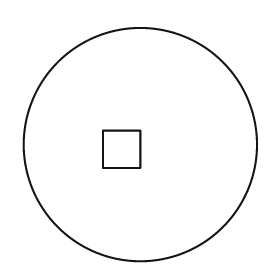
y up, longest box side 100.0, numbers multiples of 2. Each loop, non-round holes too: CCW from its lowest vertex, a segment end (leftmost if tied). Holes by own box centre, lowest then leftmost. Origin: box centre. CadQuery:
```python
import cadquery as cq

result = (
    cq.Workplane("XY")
    .moveTo(0.0, 0.0)
    .circle(50.0)
    .moveTo(-16.0, -10.0)
    .lineTo(0.0, -10.0)
    .lineTo(0.0, 6.0)
    .lineTo(-16.0, 6.0)
    .close()
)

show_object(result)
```